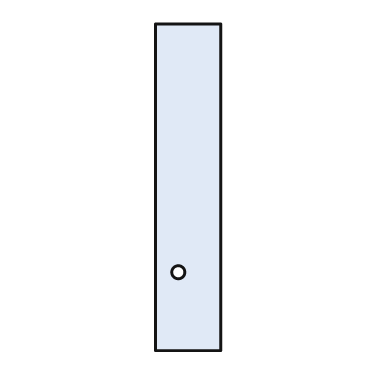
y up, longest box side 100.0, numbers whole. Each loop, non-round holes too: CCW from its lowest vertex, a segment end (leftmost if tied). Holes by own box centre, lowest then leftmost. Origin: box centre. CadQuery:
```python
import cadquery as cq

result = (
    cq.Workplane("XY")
    .moveTo(-10.0, -50.0)
    .lineTo(10.0, -50.0)
    .lineTo(10.0, 50.0)
    .lineTo(-10.0, 50.0)
    .close()
    .moveTo(-3.0, -26.0)
    .circle(2.0)
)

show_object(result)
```